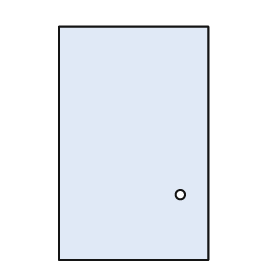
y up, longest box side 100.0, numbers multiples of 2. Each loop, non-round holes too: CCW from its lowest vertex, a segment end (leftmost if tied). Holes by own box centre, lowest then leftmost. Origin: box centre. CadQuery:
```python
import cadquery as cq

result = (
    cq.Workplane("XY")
    .moveTo(-32.0, -50.0)
    .lineTo(32.0, -50.0)
    .lineTo(32.0, 50.0)
    .lineTo(-32.0, 50.0)
    .close()
    .moveTo(20.0, -22.0)
    .circle(2.0)
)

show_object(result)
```